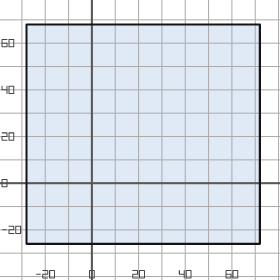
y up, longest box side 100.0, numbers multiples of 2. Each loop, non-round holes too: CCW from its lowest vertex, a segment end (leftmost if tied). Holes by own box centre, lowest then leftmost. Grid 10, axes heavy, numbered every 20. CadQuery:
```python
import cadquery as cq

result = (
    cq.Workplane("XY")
    .moveTo(-28.0, -26.0)
    .lineTo(72.0, -26.0)
    .lineTo(72.0, 68.0)
    .lineTo(-28.0, 68.0)
    .close()
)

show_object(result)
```